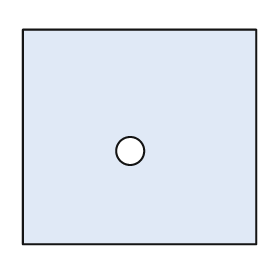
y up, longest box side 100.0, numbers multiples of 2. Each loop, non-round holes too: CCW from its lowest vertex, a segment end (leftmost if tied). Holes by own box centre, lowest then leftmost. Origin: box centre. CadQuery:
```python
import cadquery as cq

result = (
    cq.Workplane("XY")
    .moveTo(-50.0, -46.0)
    .lineTo(50.0, -46.0)
    .lineTo(50.0, 46.0)
    .lineTo(-50.0, 46.0)
    .close()
    .moveTo(-4.0, -6.0)
    .circle(6.0)
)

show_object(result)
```